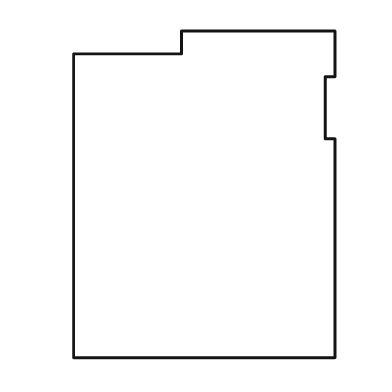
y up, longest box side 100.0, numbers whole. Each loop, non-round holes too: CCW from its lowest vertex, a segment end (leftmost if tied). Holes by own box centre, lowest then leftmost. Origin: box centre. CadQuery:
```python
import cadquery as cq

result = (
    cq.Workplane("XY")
    .moveTo(-40.0, -50.0)
    .lineTo(40.0, -50.0)
    .lineTo(40.0, 17.0)
    .lineTo(37.0, 17.0)
    .lineTo(37.0, 36.0)
    .lineTo(40.0, 36.0)
    .lineTo(40.0, 50.0)
    .lineTo(-7.0, 50.0)
    .lineTo(-7.0, 43.0)
    .lineTo(-40.0, 43.0)
    .close()
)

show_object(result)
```